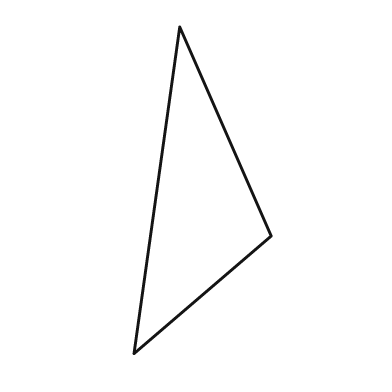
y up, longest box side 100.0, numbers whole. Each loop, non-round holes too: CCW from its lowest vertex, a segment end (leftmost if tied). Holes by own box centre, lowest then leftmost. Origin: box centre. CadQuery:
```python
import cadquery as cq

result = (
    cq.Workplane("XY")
    .moveTo(-21.0, -50.0)
    .lineTo(21.0, -14.0)
    .lineTo(-7.0, 50.0)
    .close()
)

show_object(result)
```